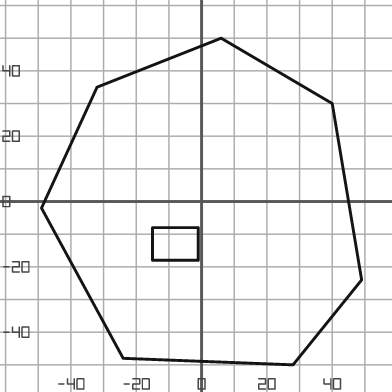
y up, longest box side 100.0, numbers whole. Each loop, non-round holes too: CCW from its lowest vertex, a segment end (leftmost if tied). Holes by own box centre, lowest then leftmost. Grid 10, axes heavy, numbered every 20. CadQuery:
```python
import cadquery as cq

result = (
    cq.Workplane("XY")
    .moveTo(28.0, -50.0)
    .lineTo(49.0, -24.0)
    .lineTo(40.0, 30.0)
    .lineTo(6.0, 50.0)
    .lineTo(-32.0, 35.0)
    .lineTo(-49.0, -2.0)
    .lineTo(-24.0, -48.0)
    .close()
    .moveTo(-15.0, -18.0)
    .lineTo(-1.0, -18.0)
    .lineTo(-1.0, -8.0)
    .lineTo(-15.0, -8.0)
    .close()
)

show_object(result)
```